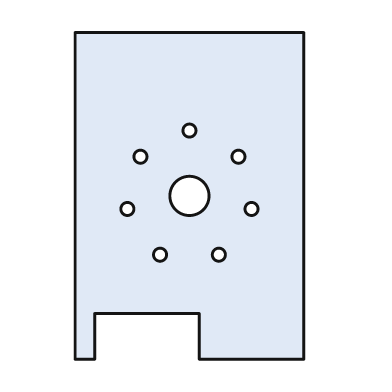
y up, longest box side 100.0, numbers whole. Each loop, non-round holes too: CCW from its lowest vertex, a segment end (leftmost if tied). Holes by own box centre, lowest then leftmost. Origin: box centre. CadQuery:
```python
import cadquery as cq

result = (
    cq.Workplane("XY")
    .moveTo(-35.0, -50.0)
    .lineTo(-29.0, -50.0)
    .lineTo(-29.0, -36.0)
    .lineTo(3.0, -36.0)
    .lineTo(3.0, -50.0)
    .lineTo(35.0, -50.0)
    .lineTo(35.0, 50.0)
    .lineTo(-35.0, 50.0)
    .close()
    .moveTo(-9.0, -18.0)
    .circle(2.0)
    .moveTo(9.0, -18.0)
    .circle(2.0)
    .moveTo(-19.0, -4.0)
    .circle(2.0)
    .moveTo(19.0, -4.0)
    .circle(2.0)
    .moveTo(0.0, 0.0)
    .circle(6.0)
    .moveTo(-15.0, 12.0)
    .circle(2.0)
    .moveTo(15.0, 12.0)
    .circle(2.0)
    .moveTo(0.0, 20.0)
    .circle(2.0)
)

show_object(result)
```